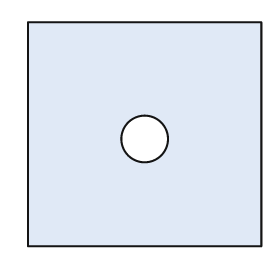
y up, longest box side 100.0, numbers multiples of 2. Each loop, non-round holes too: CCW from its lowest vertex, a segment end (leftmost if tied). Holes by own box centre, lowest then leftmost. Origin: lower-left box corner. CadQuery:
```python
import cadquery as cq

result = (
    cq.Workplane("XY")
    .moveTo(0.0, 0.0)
    .lineTo(100.0, 0.0)
    .lineTo(100.0, 96.0)
    .lineTo(0.0, 96.0)
    .close()
    .moveTo(50.0, 46.0)
    .circle(10.0)
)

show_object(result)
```